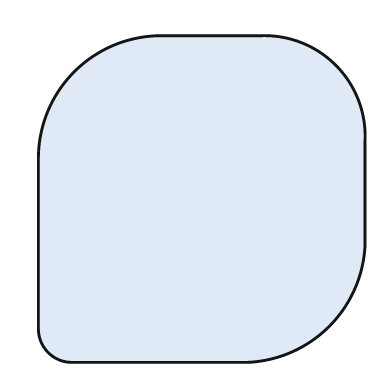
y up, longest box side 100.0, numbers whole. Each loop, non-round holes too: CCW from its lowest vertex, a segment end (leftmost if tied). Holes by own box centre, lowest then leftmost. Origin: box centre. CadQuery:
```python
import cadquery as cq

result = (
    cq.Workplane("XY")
    .moveTo(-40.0, -50.0)
    .lineTo(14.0, -50.0)
    .threePointArc((39.0, -39.0), (50.0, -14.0))
    .lineTo(50.0, 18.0)
    .threePointArc((41.0, 41.0), (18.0, 50.0))
    .lineTo(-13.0, 50.0)
    .threePointArc((-39.0, 39.0), (-50.0, 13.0))
    .lineTo(-50.0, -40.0)
    .threePointArc((-47.0, -47.0), (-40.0, -50.0))
    .close()
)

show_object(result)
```